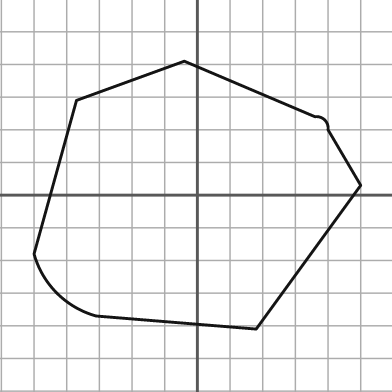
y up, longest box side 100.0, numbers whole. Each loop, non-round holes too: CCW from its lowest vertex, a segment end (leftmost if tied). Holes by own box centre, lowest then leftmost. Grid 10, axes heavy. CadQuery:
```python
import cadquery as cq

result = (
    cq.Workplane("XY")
    .moveTo(18.0, -41.0)
    .lineTo(50.0, 3.0)
    .lineTo(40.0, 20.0)
    .threePointArc((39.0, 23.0), (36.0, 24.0))
    .lineTo(-4.0, 41.0)
    .lineTo(-37.0, 29.0)
    .lineTo(-50.0, -18.0)
    .threePointArc((-43.0, -30.0), (-31.0, -37.0))
    .close()
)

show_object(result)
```